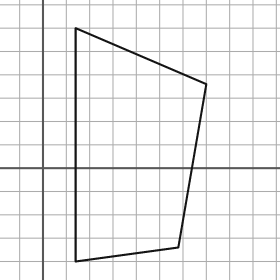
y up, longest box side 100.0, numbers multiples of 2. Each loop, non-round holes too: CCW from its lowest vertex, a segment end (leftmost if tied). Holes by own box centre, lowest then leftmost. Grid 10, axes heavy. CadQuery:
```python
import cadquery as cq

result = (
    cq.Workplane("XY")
    .moveTo(14.0, -40.0)
    .lineTo(58.0, -34.0)
    .lineTo(70.0, 36.0)
    .lineTo(14.0, 60.0)
    .close()
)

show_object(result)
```